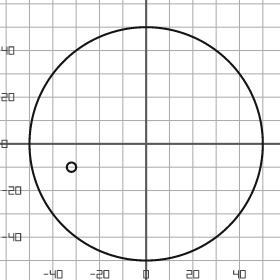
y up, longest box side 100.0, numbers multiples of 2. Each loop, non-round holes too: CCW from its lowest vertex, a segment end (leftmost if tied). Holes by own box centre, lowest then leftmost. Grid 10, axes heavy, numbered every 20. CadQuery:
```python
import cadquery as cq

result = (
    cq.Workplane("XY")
    .moveTo(0.0, 0.0)
    .circle(50.0)
    .moveTo(-32.0, -10.0)
    .circle(2.0)
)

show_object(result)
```